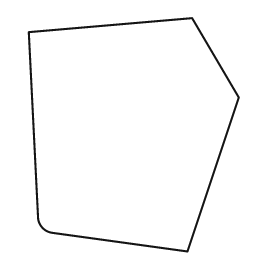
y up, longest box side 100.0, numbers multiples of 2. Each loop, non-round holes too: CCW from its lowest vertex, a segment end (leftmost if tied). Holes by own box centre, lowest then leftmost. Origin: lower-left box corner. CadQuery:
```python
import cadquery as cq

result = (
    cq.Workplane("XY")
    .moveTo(68.0, 0.0)
    .lineTo(90.0, 66.0)
    .lineTo(70.0, 100.0)
    .lineTo(0.0, 94.0)
    .lineTo(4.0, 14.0)
    .threePointArc((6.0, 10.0), (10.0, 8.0))
    .close()
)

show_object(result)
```